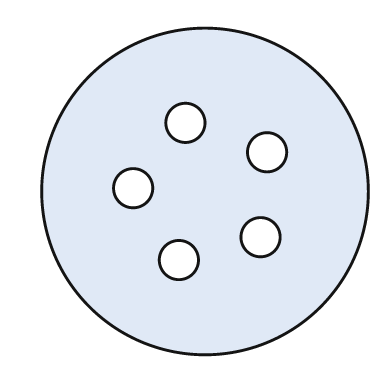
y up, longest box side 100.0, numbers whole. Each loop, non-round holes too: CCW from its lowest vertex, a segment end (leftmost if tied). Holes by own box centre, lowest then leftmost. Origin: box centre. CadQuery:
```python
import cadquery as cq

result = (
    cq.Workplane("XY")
    .moveTo(0.0, 0.0)
    .circle(50.0)
    .moveTo(-8.0, -21.0)
    .circle(6.0)
    .moveTo(17.0, -14.0)
    .circle(6.0)
    .moveTo(-22.0, 1.0)
    .circle(6.0)
    .moveTo(19.0, 12.0)
    .circle(6.0)
    .moveTo(-6.0, 21.0)
    .circle(6.0)
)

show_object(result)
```